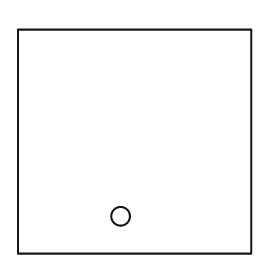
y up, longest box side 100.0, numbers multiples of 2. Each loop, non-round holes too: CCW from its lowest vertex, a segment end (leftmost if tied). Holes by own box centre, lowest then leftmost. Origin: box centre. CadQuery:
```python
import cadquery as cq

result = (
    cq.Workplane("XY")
    .moveTo(-50.0, -48.0)
    .lineTo(50.0, -48.0)
    .lineTo(50.0, 48.0)
    .lineTo(-50.0, 48.0)
    .close()
    .moveTo(-6.0, -32.0)
    .circle(4.0)
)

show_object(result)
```